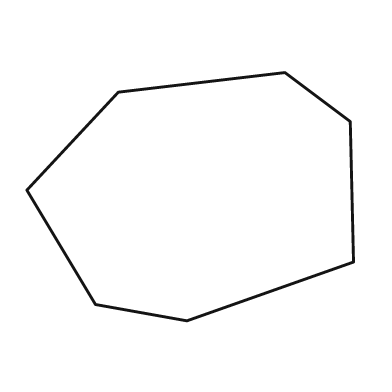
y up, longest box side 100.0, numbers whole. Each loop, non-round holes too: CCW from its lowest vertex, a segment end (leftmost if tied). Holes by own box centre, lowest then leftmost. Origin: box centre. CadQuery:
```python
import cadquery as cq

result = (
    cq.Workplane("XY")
    .moveTo(-1.0, -38.0)
    .lineTo(50.0, -20.0)
    .lineTo(49.0, 23.0)
    .lineTo(29.0, 38.0)
    .lineTo(-22.0, 32.0)
    .lineTo(-50.0, 2.0)
    .lineTo(-29.0, -33.0)
    .close()
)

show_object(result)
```